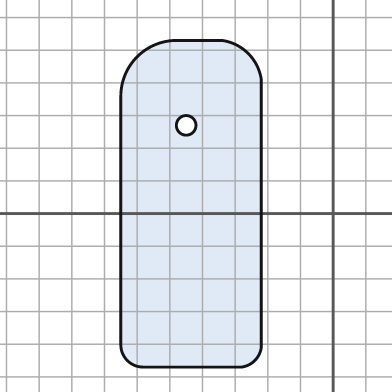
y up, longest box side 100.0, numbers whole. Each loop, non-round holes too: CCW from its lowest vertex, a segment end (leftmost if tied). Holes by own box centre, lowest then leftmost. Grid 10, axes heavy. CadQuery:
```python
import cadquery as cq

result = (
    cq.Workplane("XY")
    .moveTo(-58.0, -47.0)
    .lineTo(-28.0, -47.0)
    .threePointArc((-24.0, -45.0), (-22.0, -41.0))
    .lineTo(-22.0, 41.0)
    .threePointArc((-26.0, 49.0), (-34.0, 53.0))
    .lineTo(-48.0, 53.0)
    .threePointArc((-60.0, 48.0), (-65.0, 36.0))
    .lineTo(-65.0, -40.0)
    .threePointArc((-63.0, -45.0), (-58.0, -47.0))
    .close()
    .moveTo(-45.0, 27.0)
    .circle(3.0)
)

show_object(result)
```